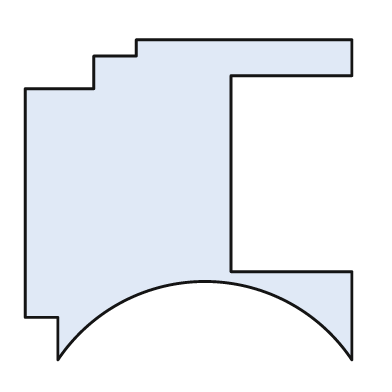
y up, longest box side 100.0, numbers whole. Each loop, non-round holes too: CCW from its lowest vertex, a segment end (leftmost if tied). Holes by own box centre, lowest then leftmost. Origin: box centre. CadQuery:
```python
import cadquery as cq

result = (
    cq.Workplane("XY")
    .moveTo(-40.0, -49.0)
    .threePointArc((5.0, -25.0), (50.0, -49.0))
    .lineTo(50.0, -22.0)
    .lineTo(13.0, -22.0)
    .lineTo(13.0, 38.0)
    .lineTo(50.0, 38.0)
    .lineTo(50.0, 49.0)
    .lineTo(-16.0, 49.0)
    .lineTo(-16.0, 44.0)
    .lineTo(-29.0, 44.0)
    .lineTo(-29.0, 34.0)
    .lineTo(-50.0, 34.0)
    .lineTo(-50.0, -36.0)
    .lineTo(-40.0, -36.0)
    .close()
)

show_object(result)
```